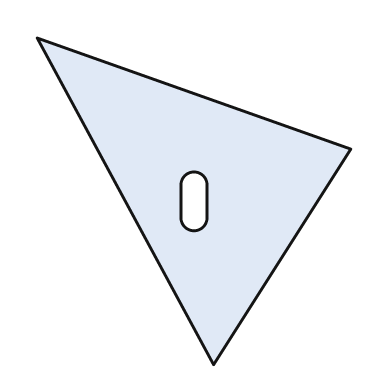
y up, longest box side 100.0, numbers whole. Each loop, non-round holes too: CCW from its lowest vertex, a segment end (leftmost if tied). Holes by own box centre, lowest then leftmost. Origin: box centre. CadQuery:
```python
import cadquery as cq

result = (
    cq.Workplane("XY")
    .moveTo(6.0, -50.0)
    .lineTo(48.0, 16.0)
    .lineTo(-48.0, 50.0)
    .close()
    .moveTo(-4.0, -5.0)
    .threePointArc((0.0, -9.0), (4.0, -5.0))
    .lineTo(4.0, 5.0)
    .threePointArc((0.0, 9.0), (-4.0, 5.0))
    .close()
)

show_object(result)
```